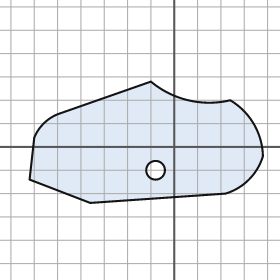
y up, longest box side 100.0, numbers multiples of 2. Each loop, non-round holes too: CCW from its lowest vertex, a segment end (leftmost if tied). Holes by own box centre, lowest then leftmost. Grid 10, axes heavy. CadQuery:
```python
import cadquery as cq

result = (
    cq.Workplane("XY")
    .moveTo(-36.0, -24.0)
    .lineTo(22.0, -20.0)
    .threePointArc((32.0, -14.0), (38.0, -4.0))
    .threePointArc((34.0, 10.0), (24.0, 20.0))
    .threePointArc((6.0, 20.0), (-10.0, 28.0))
    .lineTo(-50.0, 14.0)
    .threePointArc((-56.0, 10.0), (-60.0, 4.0))
    .lineTo(-62.0, -14.0)
    .close()
    .moveTo(-8.0, -10.0)
    .circle(4.0)
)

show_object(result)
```